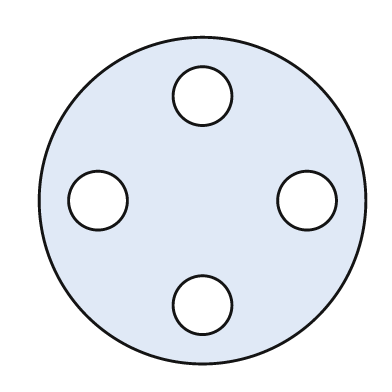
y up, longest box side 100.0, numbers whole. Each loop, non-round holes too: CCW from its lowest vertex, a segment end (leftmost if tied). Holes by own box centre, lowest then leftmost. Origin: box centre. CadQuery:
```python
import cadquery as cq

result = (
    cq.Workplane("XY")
    .moveTo(0.0, 0.0)
    .circle(50.0)
    .moveTo(0.0, -32.0)
    .circle(9.0)
    .moveTo(-32.0, 0.0)
    .circle(9.0)
    .moveTo(32.0, 0.0)
    .circle(9.0)
    .moveTo(0.0, 32.0)
    .circle(9.0)
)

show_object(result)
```